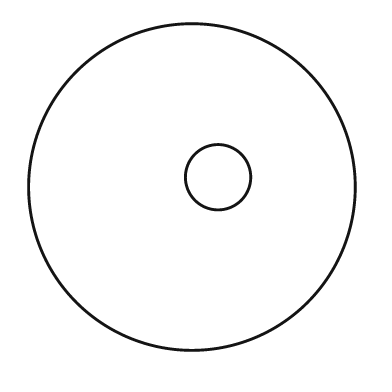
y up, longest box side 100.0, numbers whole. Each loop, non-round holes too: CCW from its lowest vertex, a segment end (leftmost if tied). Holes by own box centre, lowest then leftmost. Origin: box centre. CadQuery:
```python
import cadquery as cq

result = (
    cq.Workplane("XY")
    .moveTo(0.0, 0.0)
    .circle(50.0)
    .moveTo(8.0, 3.0)
    .circle(10.0)
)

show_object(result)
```